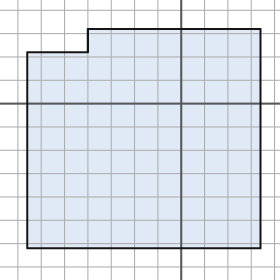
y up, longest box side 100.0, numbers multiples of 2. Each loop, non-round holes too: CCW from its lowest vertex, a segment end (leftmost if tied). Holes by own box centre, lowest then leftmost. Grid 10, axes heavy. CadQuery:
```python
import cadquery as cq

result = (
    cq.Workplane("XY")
    .moveTo(-66.0, -62.0)
    .lineTo(34.0, -62.0)
    .lineTo(34.0, 32.0)
    .lineTo(-40.0, 32.0)
    .lineTo(-40.0, 22.0)
    .lineTo(-66.0, 22.0)
    .close()
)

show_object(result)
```